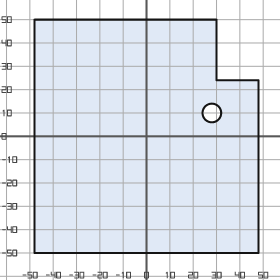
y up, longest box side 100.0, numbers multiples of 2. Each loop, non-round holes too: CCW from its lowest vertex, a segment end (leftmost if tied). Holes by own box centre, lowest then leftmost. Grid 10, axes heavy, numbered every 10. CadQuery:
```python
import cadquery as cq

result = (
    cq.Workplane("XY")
    .moveTo(-48.0, -50.0)
    .lineTo(48.0, -50.0)
    .lineTo(48.0, 24.0)
    .lineTo(30.0, 24.0)
    .lineTo(30.0, 50.0)
    .lineTo(-48.0, 50.0)
    .close()
    .moveTo(28.0, 10.0)
    .circle(4.0)
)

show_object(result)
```